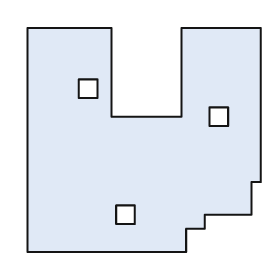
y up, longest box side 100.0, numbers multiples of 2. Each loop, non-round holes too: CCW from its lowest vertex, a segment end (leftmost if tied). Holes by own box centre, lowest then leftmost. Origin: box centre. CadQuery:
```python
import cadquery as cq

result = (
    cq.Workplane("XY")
    .moveTo(-50.0, -48.0)
    .lineTo(18.0, -48.0)
    .lineTo(18.0, -38.0)
    .lineTo(26.0, -38.0)
    .lineTo(26.0, -32.0)
    .lineTo(46.0, -32.0)
    .lineTo(46.0, -18.0)
    .lineTo(50.0, -18.0)
    .lineTo(50.0, 48.0)
    .lineTo(16.0, 48.0)
    .lineTo(16.0, 10.0)
    .lineTo(-14.0, 10.0)
    .lineTo(-14.0, 48.0)
    .lineTo(-50.0, 48.0)
    .close()
    .moveTo(-12.0, -36.0)
    .lineTo(-4.0, -36.0)
    .lineTo(-4.0, -28.0)
    .lineTo(-12.0, -28.0)
    .close()
    .moveTo(28.0, 6.0)
    .lineTo(36.0, 6.0)
    .lineTo(36.0, 14.0)
    .lineTo(28.0, 14.0)
    .close()
    .moveTo(-28.0, 18.0)
    .lineTo(-20.0, 18.0)
    .lineTo(-20.0, 26.0)
    .lineTo(-28.0, 26.0)
    .close()
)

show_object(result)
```